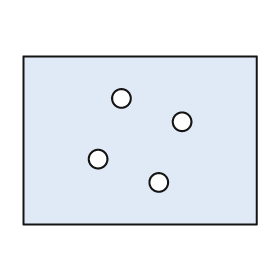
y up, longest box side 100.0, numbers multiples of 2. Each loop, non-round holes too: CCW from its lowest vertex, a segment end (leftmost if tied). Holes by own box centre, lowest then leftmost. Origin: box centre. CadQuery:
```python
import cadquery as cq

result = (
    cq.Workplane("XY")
    .moveTo(-50.0, -36.0)
    .lineTo(50.0, -36.0)
    .lineTo(50.0, 36.0)
    .lineTo(-50.0, 36.0)
    .close()
    .moveTo(8.0, -18.0)
    .circle(4.0)
    .moveTo(-18.0, -8.0)
    .circle(4.0)
    .moveTo(18.0, 8.0)
    .circle(4.0)
    .moveTo(-8.0, 18.0)
    .circle(4.0)
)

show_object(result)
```